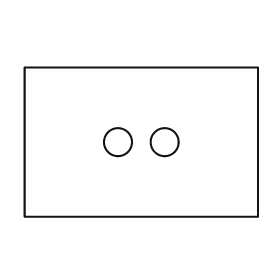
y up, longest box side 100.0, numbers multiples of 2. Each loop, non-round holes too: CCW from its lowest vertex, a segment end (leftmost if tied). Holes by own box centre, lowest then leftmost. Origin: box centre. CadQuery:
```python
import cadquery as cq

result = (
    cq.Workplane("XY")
    .moveTo(-50.0, -32.0)
    .lineTo(50.0, -32.0)
    .lineTo(50.0, 32.0)
    .lineTo(-50.0, 32.0)
    .close()
    .moveTo(-10.0, 0.0)
    .circle(6.0)
    .moveTo(10.0, 0.0)
    .circle(6.0)
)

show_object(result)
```